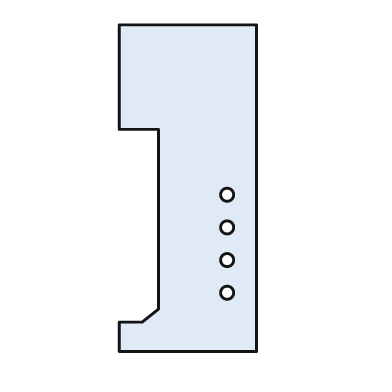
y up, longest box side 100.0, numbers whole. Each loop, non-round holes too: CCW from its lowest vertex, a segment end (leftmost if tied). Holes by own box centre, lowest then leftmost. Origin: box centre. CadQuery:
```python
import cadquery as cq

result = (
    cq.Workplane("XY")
    .moveTo(-21.0, -50.0)
    .lineTo(21.0, -50.0)
    .lineTo(21.0, 50.0)
    .lineTo(-21.0, 50.0)
    .lineTo(-21.0, 18.0)
    .lineTo(-9.0, 18.0)
    .lineTo(-9.0, -37.0)
    .lineTo(-14.0, -41.0)
    .lineTo(-21.0, -41.0)
    .close()
    .moveTo(12.0, -32.0)
    .circle(2.0)
    .moveTo(12.0, -22.0)
    .circle(2.0)
    .moveTo(12.0, -12.0)
    .circle(2.0)
    .moveTo(12.0, -2.0)
    .circle(2.0)
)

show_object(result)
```